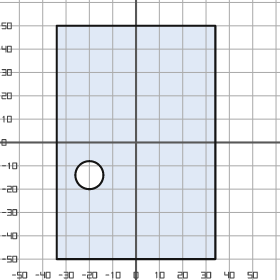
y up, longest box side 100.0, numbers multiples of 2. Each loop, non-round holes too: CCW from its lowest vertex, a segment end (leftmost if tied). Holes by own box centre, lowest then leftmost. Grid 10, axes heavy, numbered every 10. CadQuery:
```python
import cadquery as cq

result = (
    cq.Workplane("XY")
    .moveTo(-34.0, -50.0)
    .lineTo(34.0, -50.0)
    .lineTo(34.0, 50.0)
    .lineTo(-34.0, 50.0)
    .close()
    .moveTo(-20.0, -14.0)
    .circle(6.0)
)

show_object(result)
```